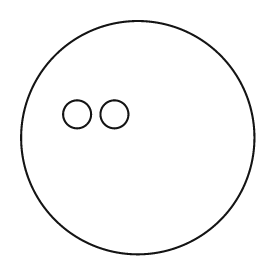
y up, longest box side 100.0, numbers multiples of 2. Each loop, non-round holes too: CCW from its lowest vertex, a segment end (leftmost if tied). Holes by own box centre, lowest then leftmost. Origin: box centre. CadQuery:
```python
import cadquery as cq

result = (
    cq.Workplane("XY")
    .moveTo(0.0, 0.0)
    .circle(50.0)
    .moveTo(-26.0, 10.0)
    .circle(6.0)
    .moveTo(-10.0, 10.0)
    .circle(6.0)
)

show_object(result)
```